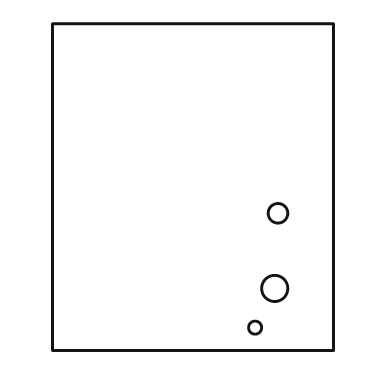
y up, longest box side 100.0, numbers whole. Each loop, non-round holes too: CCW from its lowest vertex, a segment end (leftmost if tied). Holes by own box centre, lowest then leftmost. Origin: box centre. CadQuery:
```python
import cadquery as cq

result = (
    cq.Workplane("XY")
    .moveTo(-43.0, -50.0)
    .lineTo(43.0, -50.0)
    .lineTo(43.0, 50.0)
    .lineTo(-43.0, 50.0)
    .close()
    .moveTo(19.0, -43.0)
    .circle(2.0)
    .moveTo(25.0, -31.0)
    .circle(4.0)
    .moveTo(26.0, -8.0)
    .circle(3.0)
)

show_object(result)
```